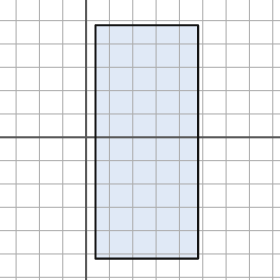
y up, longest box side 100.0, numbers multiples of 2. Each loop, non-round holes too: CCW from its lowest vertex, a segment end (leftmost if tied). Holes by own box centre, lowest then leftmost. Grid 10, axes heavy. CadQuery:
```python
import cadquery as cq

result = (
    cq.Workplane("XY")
    .moveTo(4.0, -52.0)
    .lineTo(48.0, -52.0)
    .lineTo(48.0, 48.0)
    .lineTo(4.0, 48.0)
    .close()
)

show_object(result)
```